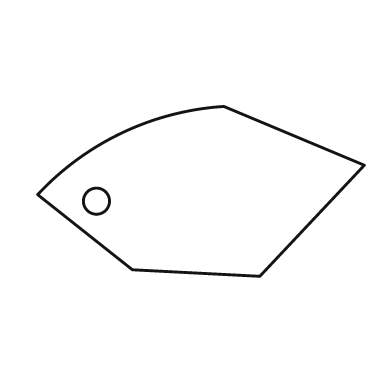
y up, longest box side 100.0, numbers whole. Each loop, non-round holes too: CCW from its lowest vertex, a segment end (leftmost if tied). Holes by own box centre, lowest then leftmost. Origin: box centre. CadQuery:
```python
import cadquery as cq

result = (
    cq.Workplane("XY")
    .moveTo(18.0, -26.0)
    .lineTo(50.0, 8.0)
    .lineTo(7.0, 26.0)
    .threePointArc((-24.0, 18.0), (-50.0, -1.0))
    .lineTo(-21.0, -24.0)
    .close()
    .moveTo(-32.0, -3.0)
    .circle(4.0)
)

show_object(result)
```